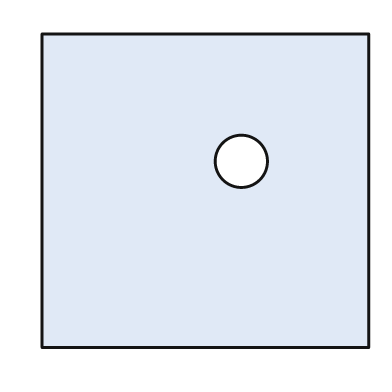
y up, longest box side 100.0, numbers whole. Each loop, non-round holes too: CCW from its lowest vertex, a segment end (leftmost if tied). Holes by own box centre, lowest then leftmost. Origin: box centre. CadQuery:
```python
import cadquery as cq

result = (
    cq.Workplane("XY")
    .moveTo(-50.0, -48.0)
    .lineTo(50.0, -48.0)
    .lineTo(50.0, 48.0)
    .lineTo(-50.0, 48.0)
    .close()
    .moveTo(11.0, 9.0)
    .circle(8.0)
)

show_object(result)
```